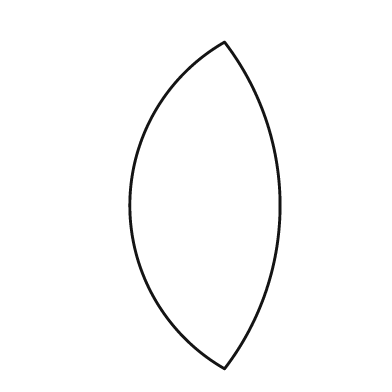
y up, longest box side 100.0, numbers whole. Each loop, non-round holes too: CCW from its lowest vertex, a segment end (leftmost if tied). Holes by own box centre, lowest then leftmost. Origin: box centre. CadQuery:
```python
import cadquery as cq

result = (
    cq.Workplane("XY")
    .moveTo(6.0, -50.0)
    .threePointArc((23.0, 0.0), (6.0, 50.0))
    .threePointArc((-23.0, 0.0), (6.0, -50.0))
    .close()
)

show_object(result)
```